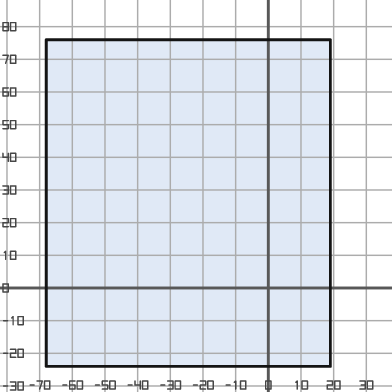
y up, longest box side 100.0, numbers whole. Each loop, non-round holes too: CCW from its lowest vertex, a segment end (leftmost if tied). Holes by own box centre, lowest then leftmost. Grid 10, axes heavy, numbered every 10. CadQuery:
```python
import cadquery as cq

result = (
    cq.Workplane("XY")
    .moveTo(-68.0, -24.0)
    .lineTo(19.0, -24.0)
    .lineTo(19.0, 76.0)
    .lineTo(-68.0, 76.0)
    .close()
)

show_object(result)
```